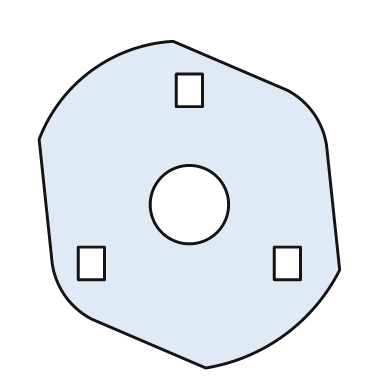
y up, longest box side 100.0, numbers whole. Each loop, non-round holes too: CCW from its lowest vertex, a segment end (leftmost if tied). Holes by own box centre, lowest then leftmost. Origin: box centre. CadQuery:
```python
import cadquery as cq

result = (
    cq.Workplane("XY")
    .moveTo(5.0, -50.0)
    .threePointArc((29.0, -40.0), (46.0, -20.0))
    .lineTo(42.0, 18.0)
    .threePointArc((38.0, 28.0), (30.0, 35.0))
    .lineTo(-5.0, 50.0)
    .threePointArc((-30.0, 41.0), (-46.0, 20.0))
    .lineTo(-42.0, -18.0)
    .threePointArc((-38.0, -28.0), (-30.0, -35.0))
    .close()
    .moveTo(-34.0, -23.0)
    .lineTo(-26.0, -23.0)
    .lineTo(-26.0, -13.0)
    .lineTo(-34.0, -13.0)
    .close()
    .moveTo(26.0, -23.0)
    .lineTo(34.0, -23.0)
    .lineTo(34.0, -13.0)
    .lineTo(26.0, -13.0)
    .close()
    .moveTo(0.0, 0.0)
    .circle(12.0)
    .moveTo(-4.0, 30.0)
    .lineTo(4.0, 30.0)
    .lineTo(4.0, 40.0)
    .lineTo(-4.0, 40.0)
    .close()
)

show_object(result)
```